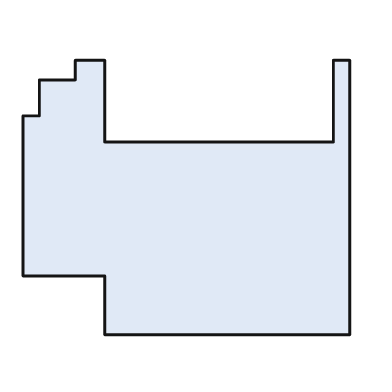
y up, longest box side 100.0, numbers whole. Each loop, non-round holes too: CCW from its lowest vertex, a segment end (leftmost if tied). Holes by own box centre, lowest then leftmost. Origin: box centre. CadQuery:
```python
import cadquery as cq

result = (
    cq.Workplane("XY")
    .moveTo(-25.0, -42.0)
    .lineTo(50.0, -42.0)
    .lineTo(50.0, 42.0)
    .lineTo(45.0, 42.0)
    .lineTo(45.0, 17.0)
    .lineTo(-25.0, 17.0)
    .lineTo(-25.0, 42.0)
    .lineTo(-34.0, 42.0)
    .lineTo(-34.0, 36.0)
    .lineTo(-45.0, 36.0)
    .lineTo(-45.0, 25.0)
    .lineTo(-50.0, 25.0)
    .lineTo(-50.0, -24.0)
    .lineTo(-25.0, -24.0)
    .close()
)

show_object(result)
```